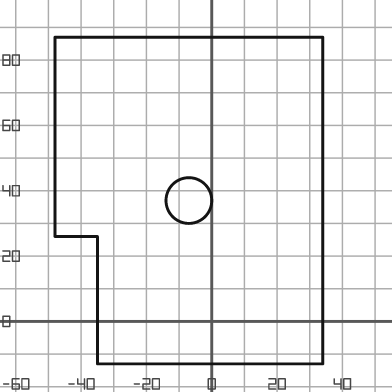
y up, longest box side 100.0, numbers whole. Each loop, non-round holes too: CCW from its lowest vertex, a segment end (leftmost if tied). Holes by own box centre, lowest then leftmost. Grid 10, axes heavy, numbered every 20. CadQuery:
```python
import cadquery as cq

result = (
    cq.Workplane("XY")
    .moveTo(-35.0, -13.0)
    .lineTo(34.0, -13.0)
    .lineTo(34.0, 87.0)
    .lineTo(-48.0, 87.0)
    .lineTo(-48.0, 26.0)
    .lineTo(-35.0, 26.0)
    .close()
    .moveTo(-7.0, 37.0)
    .circle(7.0)
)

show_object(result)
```